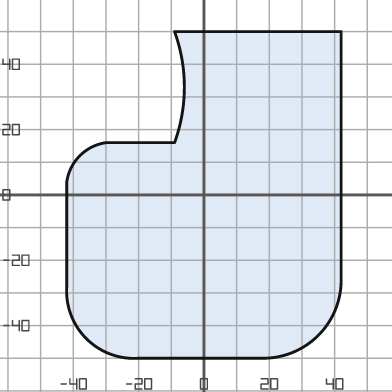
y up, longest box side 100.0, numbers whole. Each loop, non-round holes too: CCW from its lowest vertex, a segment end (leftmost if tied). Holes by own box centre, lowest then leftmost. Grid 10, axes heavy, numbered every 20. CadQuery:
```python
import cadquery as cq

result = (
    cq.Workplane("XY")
    .moveTo(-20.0, -50.0)
    .lineTo(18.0, -50.0)
    .threePointArc((35.0, -43.0), (42.0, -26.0))
    .lineTo(42.0, 50.0)
    .lineTo(-9.0, 50.0)
    .threePointArc((-6.0, 33.0), (-9.0, 16.0))
    .lineTo(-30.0, 16.0)
    .threePointArc((-38.0, 12.0), (-42.0, 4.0))
    .lineTo(-42.0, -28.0)
    .threePointArc((-36.0, -44.0), (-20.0, -50.0))
    .close()
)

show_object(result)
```